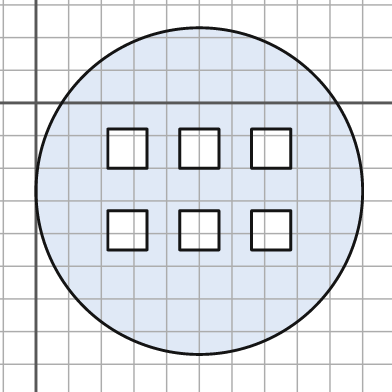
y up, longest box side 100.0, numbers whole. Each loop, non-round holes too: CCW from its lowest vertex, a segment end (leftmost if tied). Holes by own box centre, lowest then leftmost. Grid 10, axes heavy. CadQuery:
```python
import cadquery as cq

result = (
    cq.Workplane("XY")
    .moveTo(50.0, -27.0)
    .circle(50.0)
    .moveTo(22.0, -45.0)
    .lineTo(34.0, -45.0)
    .lineTo(34.0, -33.0)
    .lineTo(22.0, -33.0)
    .close()
    .moveTo(44.0, -45.0)
    .lineTo(56.0, -45.0)
    .lineTo(56.0, -33.0)
    .lineTo(44.0, -33.0)
    .close()
    .moveTo(66.0, -45.0)
    .lineTo(78.0, -45.0)
    .lineTo(78.0, -33.0)
    .lineTo(66.0, -33.0)
    .close()
    .moveTo(22.0, -20.0)
    .lineTo(34.0, -20.0)
    .lineTo(34.0, -8.0)
    .lineTo(22.0, -8.0)
    .close()
    .moveTo(44.0, -20.0)
    .lineTo(56.0, -20.0)
    .lineTo(56.0, -8.0)
    .lineTo(44.0, -8.0)
    .close()
    .moveTo(66.0, -20.0)
    .lineTo(78.0, -20.0)
    .lineTo(78.0, -8.0)
    .lineTo(66.0, -8.0)
    .close()
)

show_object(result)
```